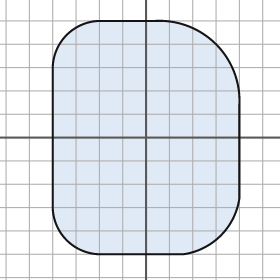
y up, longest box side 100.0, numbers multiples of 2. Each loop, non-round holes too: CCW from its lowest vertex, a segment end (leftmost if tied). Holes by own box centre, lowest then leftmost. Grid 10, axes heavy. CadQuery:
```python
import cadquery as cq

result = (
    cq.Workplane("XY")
    .moveTo(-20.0, -50.0)
    .lineTo(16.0, -50.0)
    .threePointArc((32.0, -42.0), (40.0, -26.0))
    .lineTo(40.0, 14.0)
    .threePointArc((30.0, 40.0), (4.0, 50.0))
    .lineTo(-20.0, 50.0)
    .threePointArc((-34.0, 44.0), (-40.0, 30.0))
    .lineTo(-40.0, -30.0)
    .threePointArc((-34.0, -44.0), (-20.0, -50.0))
    .close()
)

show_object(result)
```